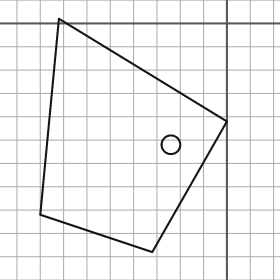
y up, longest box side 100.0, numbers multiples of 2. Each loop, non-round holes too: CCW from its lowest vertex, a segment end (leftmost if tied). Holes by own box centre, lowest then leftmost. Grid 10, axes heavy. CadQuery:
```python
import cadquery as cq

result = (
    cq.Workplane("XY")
    .moveTo(-32.0, -98.0)
    .lineTo(0.0, -42.0)
    .lineTo(-72.0, 2.0)
    .lineTo(-80.0, -82.0)
    .close()
    .moveTo(-24.0, -52.0)
    .circle(4.0)
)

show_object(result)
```